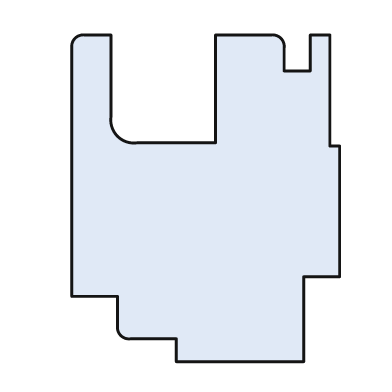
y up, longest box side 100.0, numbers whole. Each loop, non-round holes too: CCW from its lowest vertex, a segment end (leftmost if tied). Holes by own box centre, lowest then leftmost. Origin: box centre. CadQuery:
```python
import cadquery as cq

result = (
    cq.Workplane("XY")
    .moveTo(-9.0, -50.0)
    .lineTo(30.0, -50.0)
    .lineTo(30.0, -24.0)
    .lineTo(41.0, -24.0)
    .lineTo(41.0, 16.0)
    .lineTo(38.0, 16.0)
    .lineTo(38.0, 50.0)
    .lineTo(32.0, 50.0)
    .lineTo(32.0, 39.0)
    .lineTo(24.0, 39.0)
    .lineTo(24.0, 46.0)
    .threePointArc((23.0, 49.0), (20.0, 50.0))
    .lineTo(3.0, 50.0)
    .lineTo(3.0, 17.0)
    .lineTo(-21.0, 17.0)
    .threePointArc((-27.0, 19.0), (-29.0, 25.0))
    .lineTo(-29.0, 50.0)
    .lineTo(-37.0, 50.0)
    .threePointArc((-40.0, 49.0), (-41.0, 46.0))
    .lineTo(-41.0, -30.0)
    .lineTo(-27.0, -30.0)
    .lineTo(-27.0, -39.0)
    .threePointArc((-26.0, -42.0), (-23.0, -43.0))
    .lineTo(-9.0, -43.0)
    .close()
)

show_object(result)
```